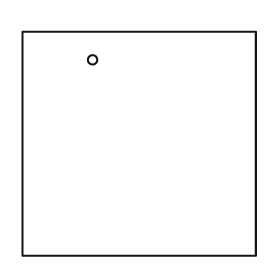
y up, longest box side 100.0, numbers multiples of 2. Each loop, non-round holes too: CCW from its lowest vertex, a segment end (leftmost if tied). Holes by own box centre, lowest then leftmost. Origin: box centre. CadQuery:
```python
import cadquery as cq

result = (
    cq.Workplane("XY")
    .moveTo(-50.0, -48.0)
    .lineTo(50.0, -48.0)
    .lineTo(50.0, 48.0)
    .lineTo(-50.0, 48.0)
    .close()
    .moveTo(-20.0, 36.0)
    .circle(2.0)
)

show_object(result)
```